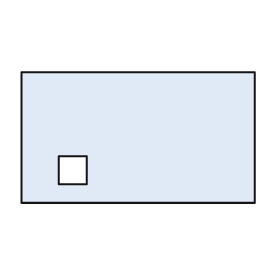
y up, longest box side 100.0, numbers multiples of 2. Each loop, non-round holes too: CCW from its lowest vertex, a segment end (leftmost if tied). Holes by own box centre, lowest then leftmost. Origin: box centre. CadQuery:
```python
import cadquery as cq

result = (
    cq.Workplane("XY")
    .moveTo(-50.0, -28.0)
    .lineTo(50.0, -28.0)
    .lineTo(50.0, 28.0)
    .lineTo(-50.0, 28.0)
    .close()
    .moveTo(-34.0, -20.0)
    .lineTo(-22.0, -20.0)
    .lineTo(-22.0, -8.0)
    .lineTo(-34.0, -8.0)
    .close()
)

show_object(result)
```